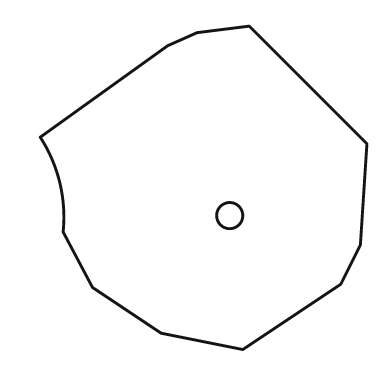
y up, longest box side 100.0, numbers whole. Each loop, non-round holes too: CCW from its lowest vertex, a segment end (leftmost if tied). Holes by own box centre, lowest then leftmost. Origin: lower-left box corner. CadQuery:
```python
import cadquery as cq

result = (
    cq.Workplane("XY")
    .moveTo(62.0, 0.0)
    .lineTo(92.0, 20.0)
    .lineTo(98.0, 32.0)
    .lineTo(100.0, 63.0)
    .lineTo(64.0, 99.0)
    .lineTo(48.0, 97.0)
    .lineTo(39.0, 93.0)
    .lineTo(0.0, 65.0)
    .threePointArc((6.0, 51.0), (7.0, 36.0))
    .lineTo(16.0, 19.0)
    .lineTo(37.0, 5.0)
    .close()
    .moveTo(58.0, 41.0)
    .circle(4.0)
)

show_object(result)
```